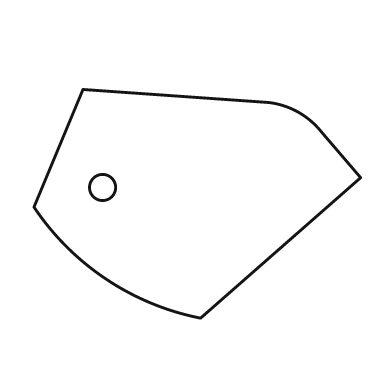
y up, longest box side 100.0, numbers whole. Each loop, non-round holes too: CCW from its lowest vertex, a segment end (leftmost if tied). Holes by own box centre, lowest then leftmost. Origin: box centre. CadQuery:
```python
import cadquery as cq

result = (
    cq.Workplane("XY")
    .moveTo(1.0, -35.0)
    .lineTo(50.0, 8.0)
    .lineTo(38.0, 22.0)
    .threePointArc((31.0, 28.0), (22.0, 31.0))
    .lineTo(-35.0, 35.0)
    .lineTo(-50.0, -1.0)
    .threePointArc((-28.0, -23.0), (1.0, -35.0))
    .close()
    .moveTo(-29.0, 5.0)
    .circle(4.0)
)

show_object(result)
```